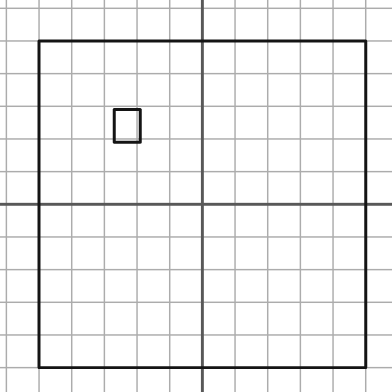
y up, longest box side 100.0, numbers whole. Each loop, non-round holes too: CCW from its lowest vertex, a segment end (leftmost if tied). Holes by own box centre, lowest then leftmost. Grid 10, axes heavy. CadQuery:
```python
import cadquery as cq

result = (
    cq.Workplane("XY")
    .moveTo(-50.0, -50.0)
    .lineTo(50.0, -50.0)
    .lineTo(50.0, 50.0)
    .lineTo(-50.0, 50.0)
    .close()
    .moveTo(-27.0, 19.0)
    .lineTo(-19.0, 19.0)
    .lineTo(-19.0, 29.0)
    .lineTo(-27.0, 29.0)
    .close()
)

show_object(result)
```